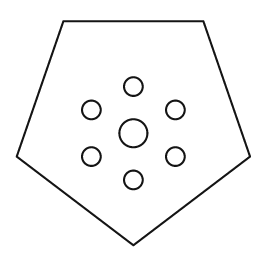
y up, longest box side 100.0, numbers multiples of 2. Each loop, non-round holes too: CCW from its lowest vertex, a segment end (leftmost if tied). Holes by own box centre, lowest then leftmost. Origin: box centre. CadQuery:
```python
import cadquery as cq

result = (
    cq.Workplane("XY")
    .moveTo(0.0, -48.0)
    .lineTo(50.0, -10.0)
    .lineTo(30.0, 48.0)
    .lineTo(-30.0, 48.0)
    .lineTo(-50.0, -10.0)
    .close()
    .moveTo(0.0, -20.0)
    .circle(4.0)
    .moveTo(-18.0, -10.0)
    .circle(4.0)
    .moveTo(18.0, -10.0)
    .circle(4.0)
    .moveTo(0.0, 0.0)
    .circle(6.0)
    .moveTo(-18.0, 10.0)
    .circle(4.0)
    .moveTo(18.0, 10.0)
    .circle(4.0)
    .moveTo(0.0, 20.0)
    .circle(4.0)
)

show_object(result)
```